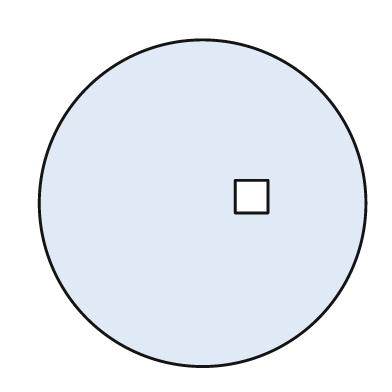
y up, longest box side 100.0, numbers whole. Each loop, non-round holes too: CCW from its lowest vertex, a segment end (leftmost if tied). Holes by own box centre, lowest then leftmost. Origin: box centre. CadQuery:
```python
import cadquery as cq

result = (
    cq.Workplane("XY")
    .moveTo(0.0, 0.0)
    .circle(50.0)
    .moveTo(10.0, -3.0)
    .lineTo(20.0, -3.0)
    .lineTo(20.0, 7.0)
    .lineTo(10.0, 7.0)
    .close()
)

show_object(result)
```